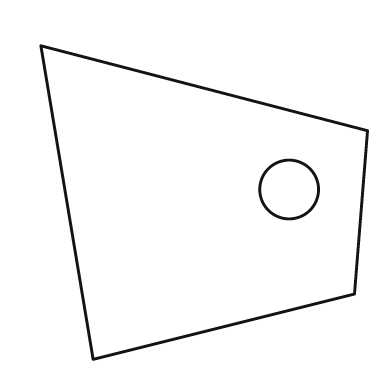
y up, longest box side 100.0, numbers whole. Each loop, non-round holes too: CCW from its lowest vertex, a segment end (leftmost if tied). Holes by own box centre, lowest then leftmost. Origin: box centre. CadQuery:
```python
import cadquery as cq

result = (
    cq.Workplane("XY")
    .moveTo(-34.0, -48.0)
    .lineTo(46.0, -28.0)
    .lineTo(50.0, 22.0)
    .lineTo(-50.0, 48.0)
    .close()
    .moveTo(26.0, 4.0)
    .circle(9.0)
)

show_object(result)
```